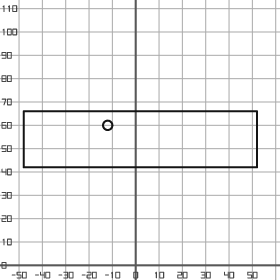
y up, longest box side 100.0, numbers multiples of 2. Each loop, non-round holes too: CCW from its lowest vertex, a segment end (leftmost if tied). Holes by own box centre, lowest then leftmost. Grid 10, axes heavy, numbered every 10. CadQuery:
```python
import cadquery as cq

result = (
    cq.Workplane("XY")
    .moveTo(-48.0, 42.0)
    .lineTo(52.0, 42.0)
    .lineTo(52.0, 66.0)
    .lineTo(-48.0, 66.0)
    .close()
    .moveTo(-12.0, 60.0)
    .circle(2.0)
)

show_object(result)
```